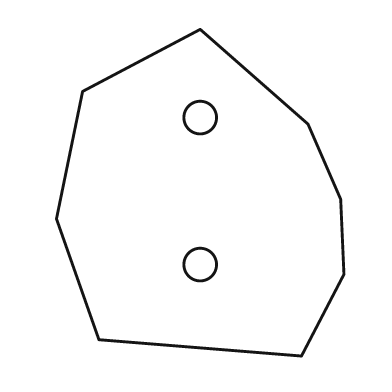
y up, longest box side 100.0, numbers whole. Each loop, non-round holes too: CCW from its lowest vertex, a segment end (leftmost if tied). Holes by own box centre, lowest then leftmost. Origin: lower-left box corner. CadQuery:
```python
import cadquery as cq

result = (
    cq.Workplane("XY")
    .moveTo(75.0, 0.0)
    .lineTo(88.0, 25.0)
    .lineTo(87.0, 48.0)
    .lineTo(77.0, 71.0)
    .lineTo(44.0, 100.0)
    .lineTo(8.0, 81.0)
    .lineTo(0.0, 42.0)
    .lineTo(13.0, 5.0)
    .close()
    .moveTo(44.0, 28.0)
    .circle(5.0)
    .moveTo(44.0, 73.0)
    .circle(5.0)
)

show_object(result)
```